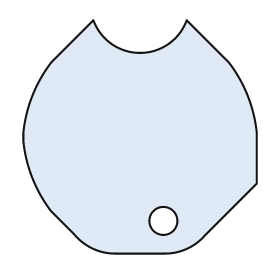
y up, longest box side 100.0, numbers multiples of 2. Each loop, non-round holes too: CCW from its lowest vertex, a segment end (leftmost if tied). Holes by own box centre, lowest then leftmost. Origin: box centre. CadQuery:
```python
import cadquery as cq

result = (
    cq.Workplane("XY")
    .moveTo(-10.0, -50.0)
    .lineTo(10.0, -50.0)
    .threePointArc((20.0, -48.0), (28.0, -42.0))
    .lineTo(50.0, -20.0)
    .lineTo(50.0, 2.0)
    .threePointArc((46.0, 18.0), (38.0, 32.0))
    .lineTo(20.0, 50.0)
    .threePointArc((0.0, 36.0), (-20.0, 50.0))
    .lineTo(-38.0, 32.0)
    .threePointArc((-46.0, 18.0), (-50.0, 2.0))
    .lineTo(-50.0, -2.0)
    .threePointArc((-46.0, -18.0), (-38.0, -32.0))
    .lineTo(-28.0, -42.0)
    .threePointArc((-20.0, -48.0), (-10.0, -50.0))
    .close()
    .moveTo(10.0, -36.0)
    .circle(6.0)
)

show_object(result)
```